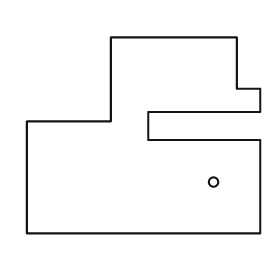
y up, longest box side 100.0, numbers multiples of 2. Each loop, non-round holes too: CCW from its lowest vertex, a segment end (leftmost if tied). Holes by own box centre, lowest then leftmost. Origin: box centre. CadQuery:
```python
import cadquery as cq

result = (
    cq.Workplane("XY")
    .moveTo(-50.0, -42.0)
    .lineTo(50.0, -42.0)
    .lineTo(50.0, -2.0)
    .lineTo(2.0, -2.0)
    .lineTo(2.0, 10.0)
    .lineTo(50.0, 10.0)
    .lineTo(50.0, 20.0)
    .lineTo(40.0, 20.0)
    .lineTo(40.0, 42.0)
    .lineTo(-14.0, 42.0)
    .lineTo(-14.0, 6.0)
    .lineTo(-50.0, 6.0)
    .close()
    .moveTo(30.0, -20.0)
    .circle(2.0)
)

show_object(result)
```